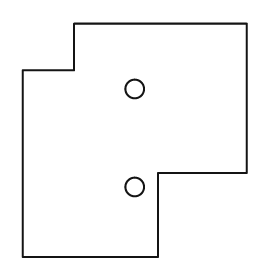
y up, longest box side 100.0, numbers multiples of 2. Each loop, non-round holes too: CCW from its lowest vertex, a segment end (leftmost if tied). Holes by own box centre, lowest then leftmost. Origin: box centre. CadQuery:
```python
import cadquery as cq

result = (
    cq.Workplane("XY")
    .moveTo(-48.0, -50.0)
    .lineTo(10.0, -50.0)
    .lineTo(10.0, -14.0)
    .lineTo(48.0, -14.0)
    .lineTo(48.0, 50.0)
    .lineTo(-26.0, 50.0)
    .lineTo(-26.0, 30.0)
    .lineTo(-48.0, 30.0)
    .close()
    .moveTo(0.0, -20.0)
    .circle(4.0)
    .moveTo(0.0, 22.0)
    .circle(4.0)
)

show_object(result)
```